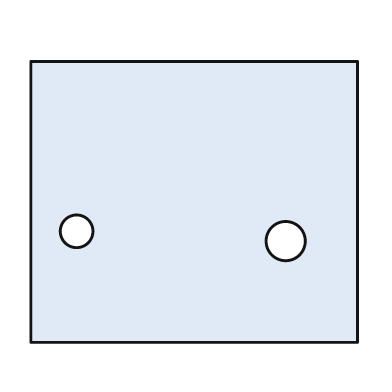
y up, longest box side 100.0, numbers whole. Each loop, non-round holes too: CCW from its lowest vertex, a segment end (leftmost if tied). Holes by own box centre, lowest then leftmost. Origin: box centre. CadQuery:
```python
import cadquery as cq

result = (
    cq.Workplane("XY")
    .moveTo(-50.0, -43.0)
    .lineTo(50.0, -43.0)
    .lineTo(50.0, 43.0)
    .lineTo(-50.0, 43.0)
    .close()
    .moveTo(28.0, -12.0)
    .circle(6.0)
    .moveTo(-36.0, -9.0)
    .circle(5.0)
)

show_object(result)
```